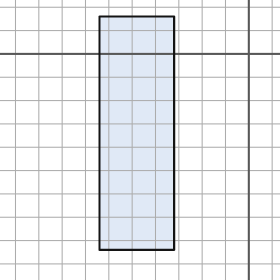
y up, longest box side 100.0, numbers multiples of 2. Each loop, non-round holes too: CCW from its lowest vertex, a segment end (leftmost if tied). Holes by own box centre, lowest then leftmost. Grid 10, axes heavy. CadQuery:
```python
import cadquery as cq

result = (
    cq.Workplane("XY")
    .moveTo(-64.0, -84.0)
    .lineTo(-32.0, -84.0)
    .lineTo(-32.0, 16.0)
    .lineTo(-64.0, 16.0)
    .close()
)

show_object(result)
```